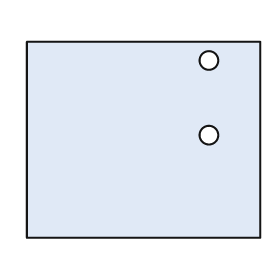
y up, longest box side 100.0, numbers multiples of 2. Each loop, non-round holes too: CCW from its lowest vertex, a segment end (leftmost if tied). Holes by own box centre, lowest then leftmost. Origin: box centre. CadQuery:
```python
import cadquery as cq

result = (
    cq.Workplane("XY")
    .moveTo(-50.0, -42.0)
    .lineTo(50.0, -42.0)
    .lineTo(50.0, 42.0)
    .lineTo(-50.0, 42.0)
    .close()
    .moveTo(28.0, 2.0)
    .circle(4.0)
    .moveTo(28.0, 34.0)
    .circle(4.0)
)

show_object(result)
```